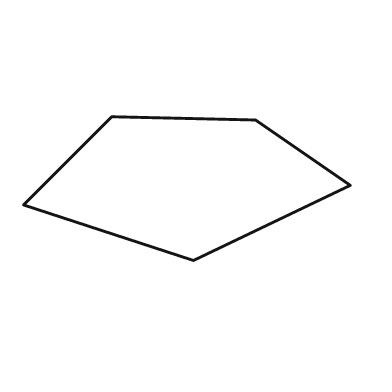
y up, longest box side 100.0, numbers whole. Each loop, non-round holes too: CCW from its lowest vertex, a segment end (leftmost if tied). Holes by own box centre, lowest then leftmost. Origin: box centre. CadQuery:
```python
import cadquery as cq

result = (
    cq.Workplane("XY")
    .moveTo(2.0, -22.0)
    .lineTo(50.0, 1.0)
    .lineTo(21.0, 21.0)
    .lineTo(-23.0, 22.0)
    .lineTo(-50.0, -5.0)
    .close()
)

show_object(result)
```